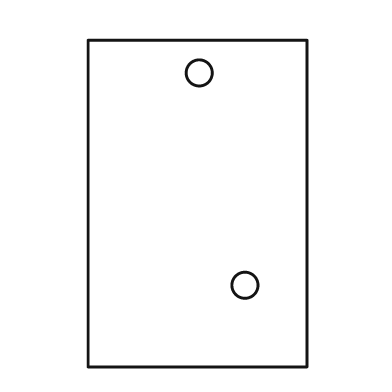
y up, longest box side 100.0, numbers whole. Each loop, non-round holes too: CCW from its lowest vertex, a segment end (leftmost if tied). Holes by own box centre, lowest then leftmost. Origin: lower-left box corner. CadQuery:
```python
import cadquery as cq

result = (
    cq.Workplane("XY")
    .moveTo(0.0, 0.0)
    .lineTo(67.0, 0.0)
    .lineTo(67.0, 100.0)
    .lineTo(0.0, 100.0)
    .close()
    .moveTo(48.0, 25.0)
    .circle(4.0)
    .moveTo(34.0, 90.0)
    .circle(4.0)
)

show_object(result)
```